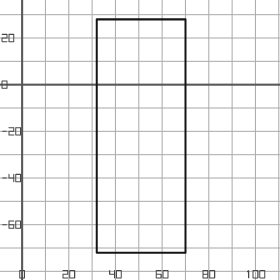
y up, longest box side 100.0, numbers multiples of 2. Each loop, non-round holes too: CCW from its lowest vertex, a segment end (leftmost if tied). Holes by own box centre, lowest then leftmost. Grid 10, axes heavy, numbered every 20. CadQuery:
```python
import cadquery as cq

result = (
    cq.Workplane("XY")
    .moveTo(32.0, -72.0)
    .lineTo(70.0, -72.0)
    .lineTo(70.0, 28.0)
    .lineTo(32.0, 28.0)
    .close()
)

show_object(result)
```